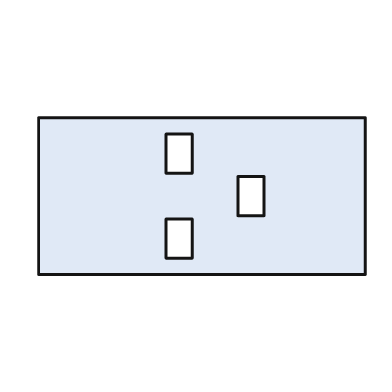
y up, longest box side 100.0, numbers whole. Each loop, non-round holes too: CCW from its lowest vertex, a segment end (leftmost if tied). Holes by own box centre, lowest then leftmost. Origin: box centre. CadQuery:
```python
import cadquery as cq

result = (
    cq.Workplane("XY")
    .moveTo(-50.0, -24.0)
    .lineTo(50.0, -24.0)
    .lineTo(50.0, 24.0)
    .lineTo(-50.0, 24.0)
    .close()
    .moveTo(-11.0, -19.0)
    .lineTo(-3.0, -19.0)
    .lineTo(-3.0, -7.0)
    .lineTo(-11.0, -7.0)
    .close()
    .moveTo(11.0, -6.0)
    .lineTo(19.0, -6.0)
    .lineTo(19.0, 6.0)
    .lineTo(11.0, 6.0)
    .close()
    .moveTo(-11.0, 7.0)
    .lineTo(-3.0, 7.0)
    .lineTo(-3.0, 19.0)
    .lineTo(-11.0, 19.0)
    .close()
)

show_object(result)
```